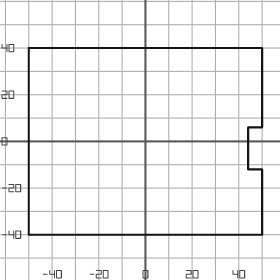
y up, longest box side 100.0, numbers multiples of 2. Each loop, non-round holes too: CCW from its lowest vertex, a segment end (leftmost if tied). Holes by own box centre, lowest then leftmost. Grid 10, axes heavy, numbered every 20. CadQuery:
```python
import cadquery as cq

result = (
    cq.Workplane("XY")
    .moveTo(-50.0, -40.0)
    .lineTo(50.0, -40.0)
    .lineTo(50.0, -12.0)
    .lineTo(44.0, -12.0)
    .lineTo(44.0, 6.0)
    .lineTo(50.0, 6.0)
    .lineTo(50.0, 40.0)
    .lineTo(-50.0, 40.0)
    .close()
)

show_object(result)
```